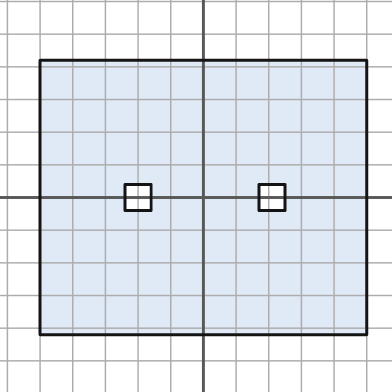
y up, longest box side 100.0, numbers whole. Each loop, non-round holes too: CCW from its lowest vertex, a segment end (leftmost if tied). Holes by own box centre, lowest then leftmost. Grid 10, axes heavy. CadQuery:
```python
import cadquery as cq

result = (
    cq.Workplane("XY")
    .moveTo(-50.0, -42.0)
    .lineTo(50.0, -42.0)
    .lineTo(50.0, 42.0)
    .lineTo(-50.0, 42.0)
    .close()
    .moveTo(-24.0, -4.0)
    .lineTo(-16.0, -4.0)
    .lineTo(-16.0, 4.0)
    .lineTo(-24.0, 4.0)
    .close()
    .moveTo(17.0, -4.0)
    .lineTo(25.0, -4.0)
    .lineTo(25.0, 4.0)
    .lineTo(17.0, 4.0)
    .close()
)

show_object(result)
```